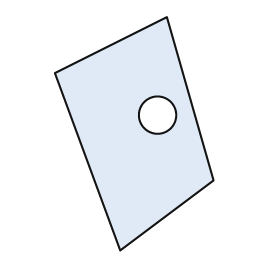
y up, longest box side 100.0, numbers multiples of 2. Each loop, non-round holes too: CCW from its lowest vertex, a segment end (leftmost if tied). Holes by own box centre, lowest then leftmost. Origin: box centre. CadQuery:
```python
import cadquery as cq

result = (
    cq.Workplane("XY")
    .moveTo(-6.0, -50.0)
    .lineTo(34.0, -20.0)
    .lineTo(14.0, 50.0)
    .lineTo(-34.0, 26.0)
    .close()
    .moveTo(10.0, 8.0)
    .circle(8.0)
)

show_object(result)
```